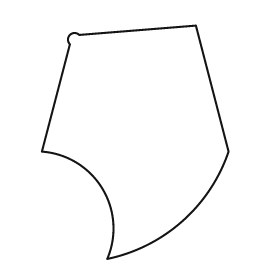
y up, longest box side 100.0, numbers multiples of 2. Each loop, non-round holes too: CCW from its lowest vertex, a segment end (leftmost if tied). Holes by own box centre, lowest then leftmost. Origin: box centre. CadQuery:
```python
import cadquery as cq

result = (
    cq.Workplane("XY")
    .moveTo(-12.0, -50.0)
    .threePointArc((20.0, -34.0), (40.0, -4.0))
    .lineTo(26.0, 50.0)
    .lineTo(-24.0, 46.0)
    .threePointArc((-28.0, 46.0), (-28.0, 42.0))
    .lineTo(-40.0, -4.0)
    .threePointArc((-14.0, -20.0), (-12.0, -50.0))
    .close()
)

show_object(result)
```